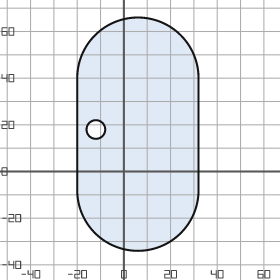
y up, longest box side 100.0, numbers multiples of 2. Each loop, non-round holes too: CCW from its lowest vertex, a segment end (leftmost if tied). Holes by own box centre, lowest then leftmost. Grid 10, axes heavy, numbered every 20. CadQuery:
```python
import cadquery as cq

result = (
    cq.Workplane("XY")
    .moveTo(-20.0, -8.0)
    .threePointArc((6.0, -34.0), (32.0, -8.0))
    .lineTo(32.0, 40.0)
    .threePointArc((6.0, 66.0), (-20.0, 40.0))
    .close()
    .moveTo(-12.0, 18.0)
    .circle(4.0)
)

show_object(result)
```